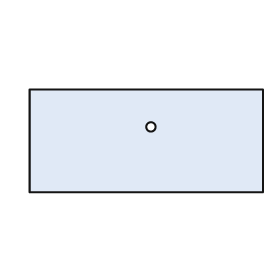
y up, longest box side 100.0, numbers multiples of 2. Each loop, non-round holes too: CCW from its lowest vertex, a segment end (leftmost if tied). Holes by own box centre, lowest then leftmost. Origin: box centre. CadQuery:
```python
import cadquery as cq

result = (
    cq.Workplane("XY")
    .moveTo(-50.0, -22.0)
    .lineTo(50.0, -22.0)
    .lineTo(50.0, 22.0)
    .lineTo(-50.0, 22.0)
    .close()
    .moveTo(2.0, 6.0)
    .circle(2.0)
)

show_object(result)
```